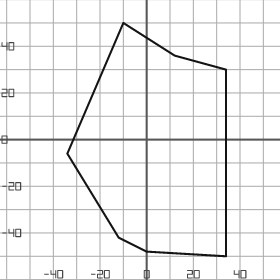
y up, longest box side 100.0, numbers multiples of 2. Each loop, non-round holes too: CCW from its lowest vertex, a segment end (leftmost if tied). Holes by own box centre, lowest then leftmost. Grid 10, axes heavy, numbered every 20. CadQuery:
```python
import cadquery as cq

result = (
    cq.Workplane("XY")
    .moveTo(34.0, -50.0)
    .lineTo(34.0, 30.0)
    .lineTo(12.0, 36.0)
    .lineTo(-10.0, 50.0)
    .lineTo(-34.0, -6.0)
    .lineTo(-12.0, -42.0)
    .lineTo(0.0, -48.0)
    .close()
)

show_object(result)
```